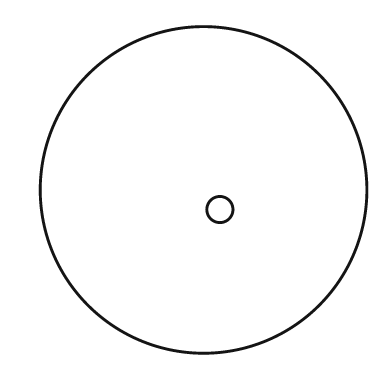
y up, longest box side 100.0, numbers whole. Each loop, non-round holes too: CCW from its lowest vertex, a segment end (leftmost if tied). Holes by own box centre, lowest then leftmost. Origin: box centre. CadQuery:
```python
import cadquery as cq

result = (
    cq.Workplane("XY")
    .moveTo(0.0, 0.0)
    .circle(50.0)
    .moveTo(5.0, -6.0)
    .circle(4.0)
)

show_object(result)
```